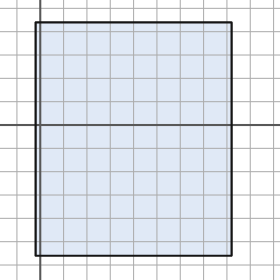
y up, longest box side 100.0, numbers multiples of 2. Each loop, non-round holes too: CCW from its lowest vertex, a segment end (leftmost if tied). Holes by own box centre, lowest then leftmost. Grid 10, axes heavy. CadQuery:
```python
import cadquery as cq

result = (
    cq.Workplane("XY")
    .moveTo(-2.0, -56.0)
    .lineTo(82.0, -56.0)
    .lineTo(82.0, 44.0)
    .lineTo(-2.0, 44.0)
    .close()
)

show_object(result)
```